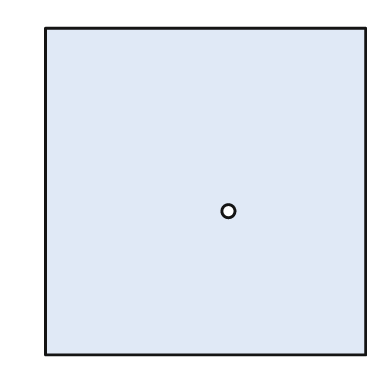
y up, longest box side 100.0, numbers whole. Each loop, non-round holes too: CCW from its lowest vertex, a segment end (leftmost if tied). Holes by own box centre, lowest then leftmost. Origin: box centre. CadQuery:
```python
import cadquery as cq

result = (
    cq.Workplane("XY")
    .moveTo(-49.0, -50.0)
    .lineTo(49.0, -50.0)
    .lineTo(49.0, 50.0)
    .lineTo(-49.0, 50.0)
    .close()
    .moveTo(7.0, -6.0)
    .circle(2.0)
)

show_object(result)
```